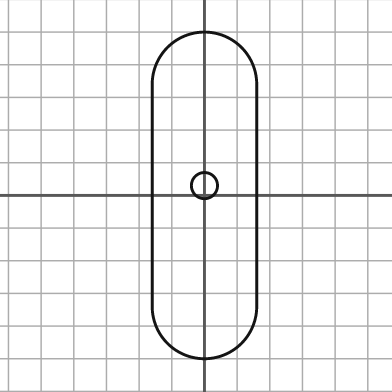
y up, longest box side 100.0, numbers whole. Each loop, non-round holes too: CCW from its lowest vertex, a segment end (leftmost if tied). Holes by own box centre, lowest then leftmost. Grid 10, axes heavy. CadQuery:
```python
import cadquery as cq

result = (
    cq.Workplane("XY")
    .moveTo(-16.0, -34.0)
    .threePointArc((0.0, -50.0), (16.0, -34.0))
    .lineTo(16.0, 34.0)
    .threePointArc((0.0, 50.0), (-16.0, 34.0))
    .close()
    .moveTo(0.0, 3.0)
    .circle(4.0)
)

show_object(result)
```